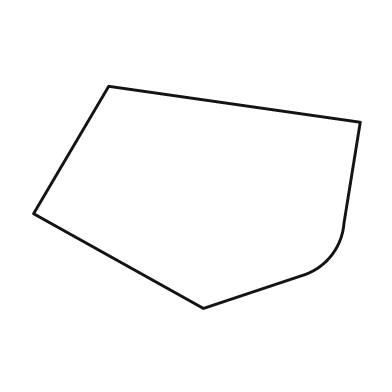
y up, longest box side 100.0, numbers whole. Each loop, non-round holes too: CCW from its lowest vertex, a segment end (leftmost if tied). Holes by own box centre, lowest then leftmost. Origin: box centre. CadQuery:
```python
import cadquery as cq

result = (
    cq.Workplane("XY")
    .moveTo(2.0, -34.0)
    .lineTo(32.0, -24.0)
    .threePointArc((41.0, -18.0), (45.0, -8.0))
    .lineTo(50.0, 23.0)
    .lineTo(-27.0, 34.0)
    .lineTo(-50.0, -5.0)
    .close()
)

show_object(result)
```